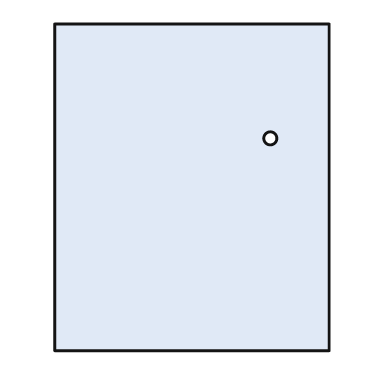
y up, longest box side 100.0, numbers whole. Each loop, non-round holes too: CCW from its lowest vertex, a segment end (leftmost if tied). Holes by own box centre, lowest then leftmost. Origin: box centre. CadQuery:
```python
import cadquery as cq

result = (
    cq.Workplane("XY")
    .moveTo(-42.0, -50.0)
    .lineTo(42.0, -50.0)
    .lineTo(42.0, 50.0)
    .lineTo(-42.0, 50.0)
    .close()
    .moveTo(24.0, 15.0)
    .circle(2.0)
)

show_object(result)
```